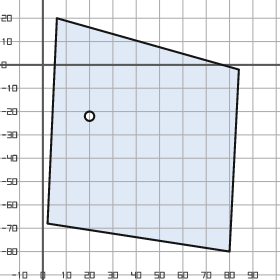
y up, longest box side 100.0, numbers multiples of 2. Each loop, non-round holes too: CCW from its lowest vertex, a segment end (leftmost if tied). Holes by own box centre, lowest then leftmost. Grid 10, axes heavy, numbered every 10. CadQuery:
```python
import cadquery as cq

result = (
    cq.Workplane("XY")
    .moveTo(80.0, -80.0)
    .lineTo(84.0, -2.0)
    .lineTo(6.0, 20.0)
    .lineTo(2.0, -68.0)
    .close()
    .moveTo(20.0, -22.0)
    .circle(2.0)
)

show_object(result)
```